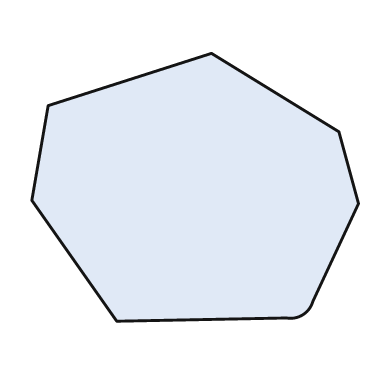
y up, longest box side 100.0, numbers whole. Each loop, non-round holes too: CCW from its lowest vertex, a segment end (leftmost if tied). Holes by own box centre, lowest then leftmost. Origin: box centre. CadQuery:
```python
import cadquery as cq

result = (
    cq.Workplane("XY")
    .moveTo(-24.0, -41.0)
    .lineTo(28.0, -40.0)
    .threePointArc((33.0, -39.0), (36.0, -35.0))
    .lineTo(50.0, -5.0)
    .lineTo(44.0, 17.0)
    .lineTo(5.0, 41.0)
    .lineTo(-45.0, 25.0)
    .lineTo(-50.0, -4.0)
    .close()
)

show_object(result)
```